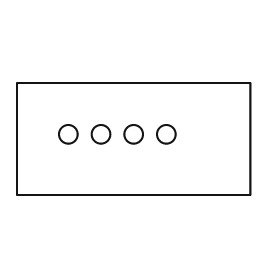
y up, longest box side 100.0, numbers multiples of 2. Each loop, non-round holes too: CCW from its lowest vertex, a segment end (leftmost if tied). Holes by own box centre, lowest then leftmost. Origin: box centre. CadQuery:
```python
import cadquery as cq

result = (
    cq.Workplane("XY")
    .moveTo(-50.0, -24.0)
    .lineTo(50.0, -24.0)
    .lineTo(50.0, 24.0)
    .lineTo(-50.0, 24.0)
    .close()
    .moveTo(-28.0, 2.0)
    .circle(4.0)
    .moveTo(-14.0, 2.0)
    .circle(4.0)
    .moveTo(0.0, 2.0)
    .circle(4.0)
    .moveTo(14.0, 2.0)
    .circle(4.0)
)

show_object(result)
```